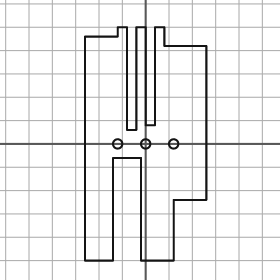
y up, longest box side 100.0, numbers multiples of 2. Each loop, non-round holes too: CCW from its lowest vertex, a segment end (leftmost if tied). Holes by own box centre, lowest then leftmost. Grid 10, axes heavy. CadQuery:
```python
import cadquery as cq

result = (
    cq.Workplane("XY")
    .moveTo(-26.0, -50.0)
    .lineTo(-14.0, -50.0)
    .lineTo(-14.0, -6.0)
    .lineTo(-2.0, -6.0)
    .lineTo(-2.0, -50.0)
    .lineTo(12.0, -50.0)
    .lineTo(12.0, -24.0)
    .lineTo(26.0, -24.0)
    .lineTo(26.0, 42.0)
    .lineTo(8.0, 42.0)
    .lineTo(8.0, 50.0)
    .lineTo(4.0, 50.0)
    .lineTo(4.0, 8.0)
    .lineTo(0.0, 8.0)
    .lineTo(0.0, 50.0)
    .lineTo(-4.0, 50.0)
    .lineTo(-4.0, 6.0)
    .lineTo(-8.0, 6.0)
    .lineTo(-8.0, 50.0)
    .lineTo(-12.0, 50.0)
    .lineTo(-12.0, 46.0)
    .lineTo(-26.0, 46.0)
    .close()
    .moveTo(-12.0, 0.0)
    .circle(2.0)
    .moveTo(0.0, 0.0)
    .circle(2.0)
    .moveTo(12.0, 0.0)
    .circle(2.0)
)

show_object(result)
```